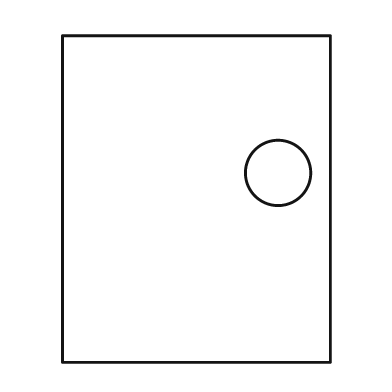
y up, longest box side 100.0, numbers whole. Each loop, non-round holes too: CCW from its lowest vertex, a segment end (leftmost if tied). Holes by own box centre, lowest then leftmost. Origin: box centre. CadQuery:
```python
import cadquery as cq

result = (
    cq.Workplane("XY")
    .moveTo(-41.0, -50.0)
    .lineTo(41.0, -50.0)
    .lineTo(41.0, 50.0)
    .lineTo(-41.0, 50.0)
    .close()
    .moveTo(25.0, 8.0)
    .circle(10.0)
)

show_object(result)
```